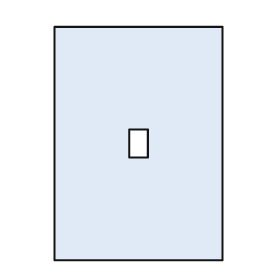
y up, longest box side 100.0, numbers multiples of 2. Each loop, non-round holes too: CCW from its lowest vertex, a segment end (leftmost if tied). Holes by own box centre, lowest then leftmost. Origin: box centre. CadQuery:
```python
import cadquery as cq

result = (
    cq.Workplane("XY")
    .moveTo(-36.0, -50.0)
    .lineTo(36.0, -50.0)
    .lineTo(36.0, 50.0)
    .lineTo(-36.0, 50.0)
    .close()
    .moveTo(-4.0, -6.0)
    .lineTo(4.0, -6.0)
    .lineTo(4.0, 6.0)
    .lineTo(-4.0, 6.0)
    .close()
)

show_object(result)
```